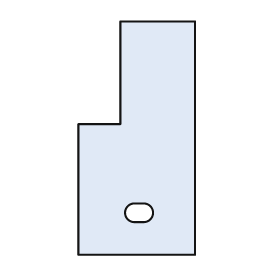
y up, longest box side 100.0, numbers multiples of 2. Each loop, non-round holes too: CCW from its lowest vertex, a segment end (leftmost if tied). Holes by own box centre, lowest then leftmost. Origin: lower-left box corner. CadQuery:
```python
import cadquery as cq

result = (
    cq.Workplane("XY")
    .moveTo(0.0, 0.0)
    .lineTo(50.0, 0.0)
    .lineTo(50.0, 100.0)
    .lineTo(18.0, 100.0)
    .lineTo(18.0, 56.0)
    .lineTo(0.0, 56.0)
    .close()
    .moveTo(24.0, 14.0)
    .lineTo(28.0, 14.0)
    .threePointArc((32.0, 18.0), (28.0, 22.0))
    .lineTo(24.0, 22.0)
    .threePointArc((20.0, 18.0), (24.0, 14.0))
    .close()
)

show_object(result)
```